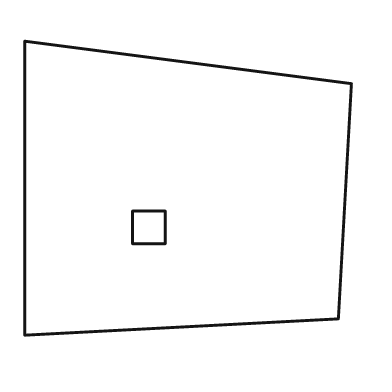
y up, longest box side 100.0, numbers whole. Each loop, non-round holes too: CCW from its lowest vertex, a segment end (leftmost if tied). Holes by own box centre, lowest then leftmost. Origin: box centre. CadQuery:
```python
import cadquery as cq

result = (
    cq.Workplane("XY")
    .moveTo(-50.0, -45.0)
    .lineTo(46.0, -40.0)
    .lineTo(50.0, 32.0)
    .lineTo(-50.0, 45.0)
    .close()
    .moveTo(-17.0, -17.0)
    .lineTo(-7.0, -17.0)
    .lineTo(-7.0, -7.0)
    .lineTo(-17.0, -7.0)
    .close()
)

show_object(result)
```